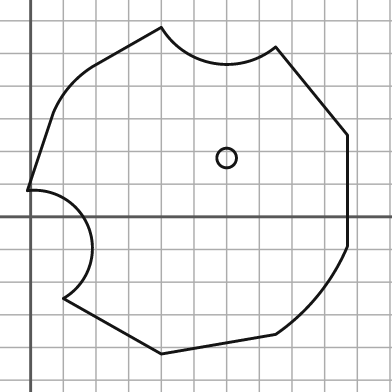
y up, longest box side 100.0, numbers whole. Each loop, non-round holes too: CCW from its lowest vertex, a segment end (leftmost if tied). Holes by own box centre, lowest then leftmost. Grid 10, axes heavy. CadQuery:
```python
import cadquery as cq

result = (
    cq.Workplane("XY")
    .moveTo(40.0, -42.0)
    .lineTo(75.0, -36.0)
    .threePointArc((88.0, -24.0), (97.0, -9.0))
    .lineTo(97.0, 25.0)
    .lineTo(75.0, 52.0)
    .threePointArc((56.0, 47.0), (40.0, 58.0))
    .lineTo(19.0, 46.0)
    .threePointArc((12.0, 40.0), (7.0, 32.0))
    .lineTo(-1.0, 8.0)
    .threePointArc((18.0, -4.0), (10.0, -25.0))
    .close()
    .moveTo(60.0, 18.0)
    .circle(3.0)
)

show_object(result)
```